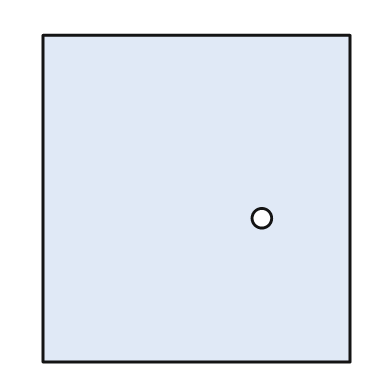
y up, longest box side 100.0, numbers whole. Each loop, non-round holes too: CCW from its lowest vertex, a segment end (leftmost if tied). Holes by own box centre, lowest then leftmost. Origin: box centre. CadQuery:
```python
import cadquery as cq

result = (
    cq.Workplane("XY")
    .moveTo(-47.0, -50.0)
    .lineTo(47.0, -50.0)
    .lineTo(47.0, 50.0)
    .lineTo(-47.0, 50.0)
    .close()
    .moveTo(20.0, -6.0)
    .circle(3.0)
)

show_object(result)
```